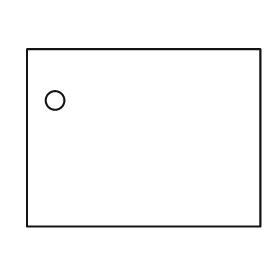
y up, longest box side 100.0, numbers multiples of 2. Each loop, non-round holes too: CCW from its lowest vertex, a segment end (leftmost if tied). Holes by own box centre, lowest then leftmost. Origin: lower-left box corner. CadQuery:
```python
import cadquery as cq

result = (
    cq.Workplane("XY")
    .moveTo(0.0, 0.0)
    .lineTo(100.0, 0.0)
    .lineTo(100.0, 76.0)
    .lineTo(0.0, 76.0)
    .close()
    .moveTo(12.0, 54.0)
    .circle(4.0)
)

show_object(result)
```